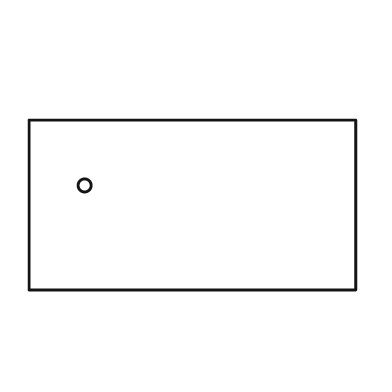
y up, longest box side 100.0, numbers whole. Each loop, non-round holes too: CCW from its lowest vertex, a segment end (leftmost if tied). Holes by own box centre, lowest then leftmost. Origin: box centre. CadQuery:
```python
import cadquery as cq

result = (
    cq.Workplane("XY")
    .moveTo(-50.0, -26.0)
    .lineTo(50.0, -26.0)
    .lineTo(50.0, 26.0)
    .lineTo(-50.0, 26.0)
    .close()
    .moveTo(-33.0, 6.0)
    .circle(2.0)
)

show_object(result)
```